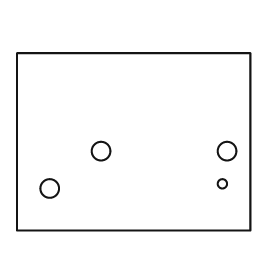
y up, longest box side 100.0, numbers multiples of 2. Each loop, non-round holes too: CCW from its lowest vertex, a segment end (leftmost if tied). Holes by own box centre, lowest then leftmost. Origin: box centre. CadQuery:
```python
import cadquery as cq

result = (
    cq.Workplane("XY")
    .moveTo(-50.0, -38.0)
    .lineTo(50.0, -38.0)
    .lineTo(50.0, 38.0)
    .lineTo(-50.0, 38.0)
    .close()
    .moveTo(-36.0, -20.0)
    .circle(4.0)
    .moveTo(38.0, -18.0)
    .circle(2.0)
    .moveTo(-14.0, -4.0)
    .circle(4.0)
    .moveTo(40.0, -4.0)
    .circle(4.0)
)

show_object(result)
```